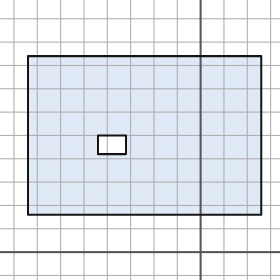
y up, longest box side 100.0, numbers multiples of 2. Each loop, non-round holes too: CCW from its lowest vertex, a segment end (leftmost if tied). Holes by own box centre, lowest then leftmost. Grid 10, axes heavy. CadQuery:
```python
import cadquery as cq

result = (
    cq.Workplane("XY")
    .moveTo(-74.0, 16.0)
    .lineTo(26.0, 16.0)
    .lineTo(26.0, 84.0)
    .lineTo(-74.0, 84.0)
    .close()
    .moveTo(-44.0, 42.0)
    .lineTo(-32.0, 42.0)
    .lineTo(-32.0, 50.0)
    .lineTo(-44.0, 50.0)
    .close()
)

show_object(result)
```